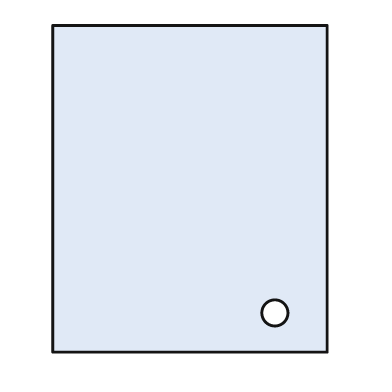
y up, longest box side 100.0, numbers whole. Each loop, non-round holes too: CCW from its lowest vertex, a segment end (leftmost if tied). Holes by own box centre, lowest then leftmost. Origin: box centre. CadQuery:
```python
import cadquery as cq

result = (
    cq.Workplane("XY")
    .moveTo(-42.0, -50.0)
    .lineTo(42.0, -50.0)
    .lineTo(42.0, 50.0)
    .lineTo(-42.0, 50.0)
    .close()
    .moveTo(26.0, -38.0)
    .circle(4.0)
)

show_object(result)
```